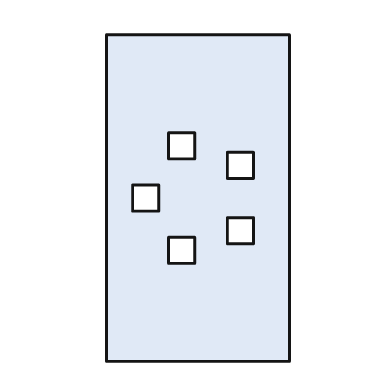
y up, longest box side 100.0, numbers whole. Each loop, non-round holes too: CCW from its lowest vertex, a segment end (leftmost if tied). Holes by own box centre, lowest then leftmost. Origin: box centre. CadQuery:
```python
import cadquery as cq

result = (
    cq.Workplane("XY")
    .moveTo(-28.0, -50.0)
    .lineTo(28.0, -50.0)
    .lineTo(28.0, 50.0)
    .lineTo(-28.0, 50.0)
    .close()
    .moveTo(-9.0, -20.0)
    .lineTo(-1.0, -20.0)
    .lineTo(-1.0, -12.0)
    .lineTo(-9.0, -12.0)
    .close()
    .moveTo(9.0, -14.0)
    .lineTo(17.0, -14.0)
    .lineTo(17.0, -6.0)
    .lineTo(9.0, -6.0)
    .close()
    .moveTo(-20.0, -4.0)
    .lineTo(-12.0, -4.0)
    .lineTo(-12.0, 4.0)
    .lineTo(-20.0, 4.0)
    .close()
    .moveTo(9.0, 6.0)
    .lineTo(17.0, 6.0)
    .lineTo(17.0, 14.0)
    .lineTo(9.0, 14.0)
    .close()
    .moveTo(-9.0, 12.0)
    .lineTo(-1.0, 12.0)
    .lineTo(-1.0, 20.0)
    .lineTo(-9.0, 20.0)
    .close()
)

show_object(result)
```